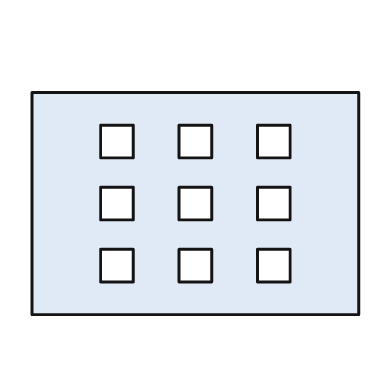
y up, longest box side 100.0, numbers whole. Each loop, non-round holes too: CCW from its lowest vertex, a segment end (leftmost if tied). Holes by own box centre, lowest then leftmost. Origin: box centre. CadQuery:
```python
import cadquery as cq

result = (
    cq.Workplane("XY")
    .moveTo(-50.0, -34.0)
    .lineTo(50.0, -34.0)
    .lineTo(50.0, 34.0)
    .lineTo(-50.0, 34.0)
    .close()
    .moveTo(-29.0, -24.0)
    .lineTo(-19.0, -24.0)
    .lineTo(-19.0, -14.0)
    .lineTo(-29.0, -14.0)
    .close()
    .moveTo(-5.0, -24.0)
    .lineTo(5.0, -24.0)
    .lineTo(5.0, -14.0)
    .lineTo(-5.0, -14.0)
    .close()
    .moveTo(19.0, -24.0)
    .lineTo(29.0, -24.0)
    .lineTo(29.0, -14.0)
    .lineTo(19.0, -14.0)
    .close()
    .moveTo(-29.0, -5.0)
    .lineTo(-19.0, -5.0)
    .lineTo(-19.0, 5.0)
    .lineTo(-29.0, 5.0)
    .close()
    .moveTo(-5.0, -5.0)
    .lineTo(5.0, -5.0)
    .lineTo(5.0, 5.0)
    .lineTo(-5.0, 5.0)
    .close()
    .moveTo(19.0, -5.0)
    .lineTo(29.0, -5.0)
    .lineTo(29.0, 5.0)
    .lineTo(19.0, 5.0)
    .close()
    .moveTo(-29.0, 14.0)
    .lineTo(-19.0, 14.0)
    .lineTo(-19.0, 24.0)
    .lineTo(-29.0, 24.0)
    .close()
    .moveTo(-5.0, 14.0)
    .lineTo(5.0, 14.0)
    .lineTo(5.0, 24.0)
    .lineTo(-5.0, 24.0)
    .close()
    .moveTo(19.0, 14.0)
    .lineTo(29.0, 14.0)
    .lineTo(29.0, 24.0)
    .lineTo(19.0, 24.0)
    .close()
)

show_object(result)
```